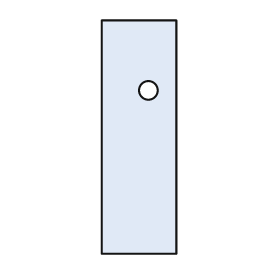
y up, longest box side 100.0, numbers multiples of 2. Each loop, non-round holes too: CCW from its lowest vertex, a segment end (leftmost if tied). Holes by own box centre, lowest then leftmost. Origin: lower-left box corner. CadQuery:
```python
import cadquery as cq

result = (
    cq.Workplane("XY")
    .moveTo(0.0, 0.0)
    .lineTo(32.0, 0.0)
    .lineTo(32.0, 100.0)
    .lineTo(0.0, 100.0)
    .close()
    .moveTo(20.0, 70.0)
    .circle(4.0)
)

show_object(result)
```